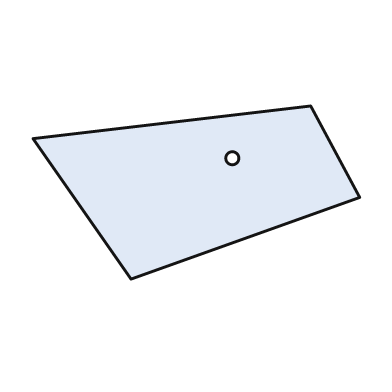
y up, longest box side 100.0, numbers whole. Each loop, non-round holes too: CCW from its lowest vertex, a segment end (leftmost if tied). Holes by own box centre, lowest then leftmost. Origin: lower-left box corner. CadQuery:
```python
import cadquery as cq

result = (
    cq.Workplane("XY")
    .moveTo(30.0, 0.0)
    .lineTo(100.0, 25.0)
    .lineTo(85.0, 53.0)
    .lineTo(0.0, 43.0)
    .close()
    .moveTo(61.0, 37.0)
    .circle(2.0)
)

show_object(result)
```